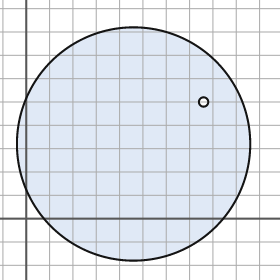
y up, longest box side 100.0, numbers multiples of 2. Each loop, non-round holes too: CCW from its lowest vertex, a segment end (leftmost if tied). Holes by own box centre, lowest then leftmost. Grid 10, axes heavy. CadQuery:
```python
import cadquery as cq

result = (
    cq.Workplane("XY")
    .moveTo(46.0, 32.0)
    .circle(50.0)
    .moveTo(76.0, 50.0)
    .circle(2.0)
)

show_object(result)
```